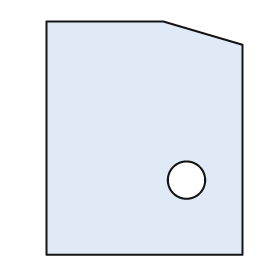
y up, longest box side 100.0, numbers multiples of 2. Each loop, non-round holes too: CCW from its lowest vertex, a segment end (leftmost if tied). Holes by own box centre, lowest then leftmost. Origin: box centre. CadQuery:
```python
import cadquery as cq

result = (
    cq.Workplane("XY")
    .moveTo(-42.0, -50.0)
    .lineTo(42.0, -50.0)
    .lineTo(42.0, 40.0)
    .lineTo(8.0, 50.0)
    .lineTo(-42.0, 50.0)
    .close()
    .moveTo(18.0, -18.0)
    .circle(8.0)
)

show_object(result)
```